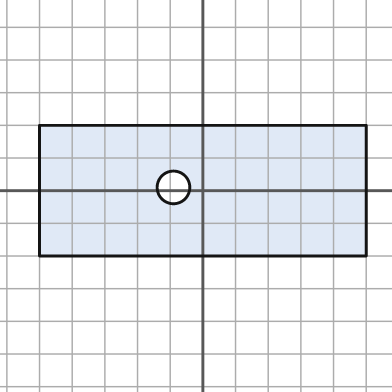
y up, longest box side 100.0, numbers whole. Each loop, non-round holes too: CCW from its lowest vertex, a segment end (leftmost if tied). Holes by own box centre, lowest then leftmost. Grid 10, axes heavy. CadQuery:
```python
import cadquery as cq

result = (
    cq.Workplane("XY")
    .moveTo(-50.0, -20.0)
    .lineTo(50.0, -20.0)
    .lineTo(50.0, 20.0)
    .lineTo(-50.0, 20.0)
    .close()
    .moveTo(-9.0, 1.0)
    .circle(5.0)
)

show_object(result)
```